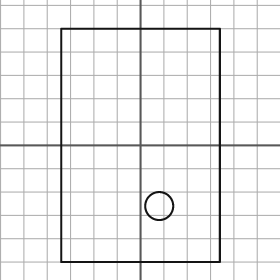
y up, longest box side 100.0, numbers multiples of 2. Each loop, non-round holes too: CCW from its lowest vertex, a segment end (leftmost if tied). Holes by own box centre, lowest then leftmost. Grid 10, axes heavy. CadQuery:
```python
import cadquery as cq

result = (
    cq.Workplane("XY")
    .moveTo(-34.0, -50.0)
    .lineTo(34.0, -50.0)
    .lineTo(34.0, 50.0)
    .lineTo(-34.0, 50.0)
    .close()
    .moveTo(8.0, -26.0)
    .circle(6.0)
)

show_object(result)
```